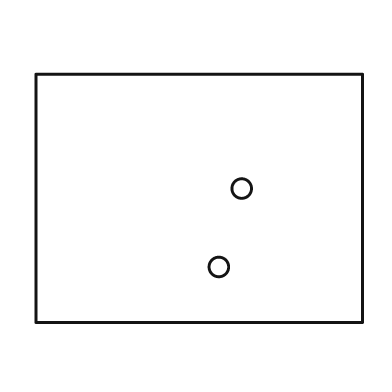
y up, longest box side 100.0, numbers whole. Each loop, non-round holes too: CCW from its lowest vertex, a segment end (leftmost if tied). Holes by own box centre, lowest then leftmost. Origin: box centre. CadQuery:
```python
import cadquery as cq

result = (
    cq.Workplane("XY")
    .moveTo(-50.0, -38.0)
    .lineTo(50.0, -38.0)
    .lineTo(50.0, 38.0)
    .lineTo(-50.0, 38.0)
    .close()
    .moveTo(6.0, -21.0)
    .circle(3.0)
    .moveTo(13.0, 3.0)
    .circle(3.0)
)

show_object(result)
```